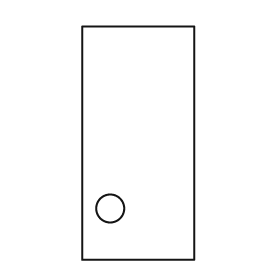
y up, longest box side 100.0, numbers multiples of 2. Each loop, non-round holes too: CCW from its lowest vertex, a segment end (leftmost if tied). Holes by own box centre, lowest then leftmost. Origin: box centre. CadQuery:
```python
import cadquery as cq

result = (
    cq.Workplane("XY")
    .moveTo(-24.0, -50.0)
    .lineTo(24.0, -50.0)
    .lineTo(24.0, 50.0)
    .lineTo(-24.0, 50.0)
    .close()
    .moveTo(-12.0, -28.0)
    .circle(6.0)
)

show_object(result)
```